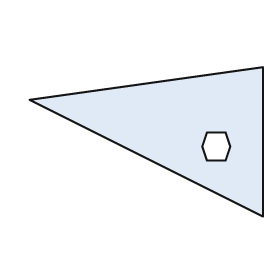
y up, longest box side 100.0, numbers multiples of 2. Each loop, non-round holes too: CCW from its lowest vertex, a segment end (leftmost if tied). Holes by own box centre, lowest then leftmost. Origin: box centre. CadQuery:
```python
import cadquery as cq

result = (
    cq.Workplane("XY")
    .moveTo(50.0, -32.0)
    .lineTo(50.0, 32.0)
    .lineTo(-50.0, 18.0)
    .close()
    .moveTo(26.0, -8.0)
    .lineTo(34.0, -8.0)
    .lineTo(36.0, -2.0)
    .lineTo(34.0, 4.0)
    .lineTo(26.0, 4.0)
    .lineTo(24.0, -2.0)
    .close()
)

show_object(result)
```